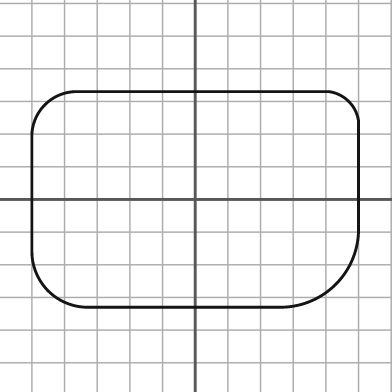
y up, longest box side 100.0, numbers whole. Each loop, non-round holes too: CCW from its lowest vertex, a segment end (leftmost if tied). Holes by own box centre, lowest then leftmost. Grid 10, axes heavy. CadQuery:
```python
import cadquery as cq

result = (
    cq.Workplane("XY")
    .moveTo(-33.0, -33.0)
    .lineTo(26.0, -33.0)
    .threePointArc((43.0, -26.0), (50.0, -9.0))
    .lineTo(50.0, 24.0)
    .threePointArc((47.0, 30.0), (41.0, 33.0))
    .lineTo(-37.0, 33.0)
    .threePointArc((-46.0, 29.0), (-50.0, 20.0))
    .lineTo(-50.0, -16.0)
    .threePointArc((-45.0, -28.0), (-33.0, -33.0))
    .close()
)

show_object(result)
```